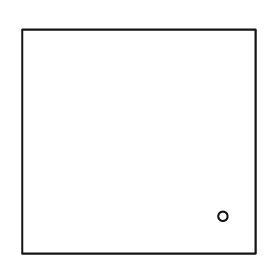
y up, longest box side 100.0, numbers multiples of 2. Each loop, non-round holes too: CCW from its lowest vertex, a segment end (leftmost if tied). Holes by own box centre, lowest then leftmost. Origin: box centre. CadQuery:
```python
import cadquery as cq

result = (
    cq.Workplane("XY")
    .moveTo(-50.0, -48.0)
    .lineTo(50.0, -48.0)
    .lineTo(50.0, 48.0)
    .lineTo(-50.0, 48.0)
    .close()
    .moveTo(36.0, -32.0)
    .circle(2.0)
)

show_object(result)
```